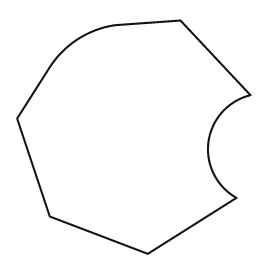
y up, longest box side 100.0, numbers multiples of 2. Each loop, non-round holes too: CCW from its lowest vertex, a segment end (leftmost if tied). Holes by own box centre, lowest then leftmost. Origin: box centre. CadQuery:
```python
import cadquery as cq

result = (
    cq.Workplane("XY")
    .moveTo(6.0, -50.0)
    .lineTo(44.0, -26.0)
    .threePointArc((32.0, -2.0), (50.0, 18.0))
    .lineTo(20.0, 50.0)
    .lineTo(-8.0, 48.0)
    .threePointArc((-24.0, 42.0), (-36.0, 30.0))
    .lineTo(-50.0, 8.0)
    .lineTo(-36.0, -34.0)
    .close()
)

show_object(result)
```